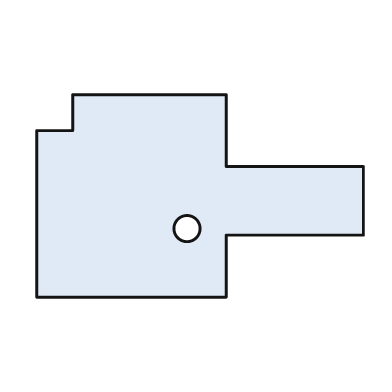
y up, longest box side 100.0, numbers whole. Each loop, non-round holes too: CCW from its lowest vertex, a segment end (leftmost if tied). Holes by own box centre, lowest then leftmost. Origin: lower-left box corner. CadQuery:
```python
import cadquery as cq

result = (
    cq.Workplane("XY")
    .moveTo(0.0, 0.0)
    .lineTo(58.0, 0.0)
    .lineTo(58.0, 19.0)
    .lineTo(100.0, 19.0)
    .lineTo(100.0, 40.0)
    .lineTo(58.0, 40.0)
    .lineTo(58.0, 62.0)
    .lineTo(11.0, 62.0)
    .lineTo(11.0, 51.0)
    .lineTo(0.0, 51.0)
    .close()
    .moveTo(46.0, 21.0)
    .circle(4.0)
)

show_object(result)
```